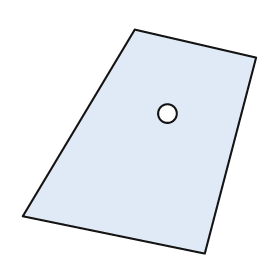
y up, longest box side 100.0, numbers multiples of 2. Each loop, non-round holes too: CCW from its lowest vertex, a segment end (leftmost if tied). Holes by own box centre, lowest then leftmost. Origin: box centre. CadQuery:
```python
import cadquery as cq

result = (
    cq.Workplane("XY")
    .moveTo(28.0, -48.0)
    .lineTo(50.0, 36.0)
    .lineTo(-2.0, 48.0)
    .lineTo(-50.0, -32.0)
    .close()
    .moveTo(12.0, 12.0)
    .circle(4.0)
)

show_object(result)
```